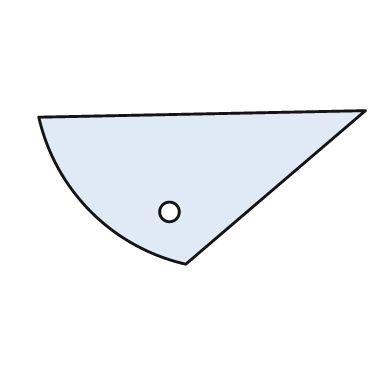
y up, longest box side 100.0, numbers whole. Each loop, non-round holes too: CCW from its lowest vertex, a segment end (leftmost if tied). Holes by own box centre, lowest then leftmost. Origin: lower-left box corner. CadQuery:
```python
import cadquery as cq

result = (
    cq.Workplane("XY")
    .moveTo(45.0, 0.0)
    .lineTo(100.0, 47.0)
    .lineTo(0.0, 45.0)
    .threePointArc((16.0, 16.0), (45.0, 0.0))
    .close()
    .moveTo(40.0, 16.0)
    .circle(3.0)
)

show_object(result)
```